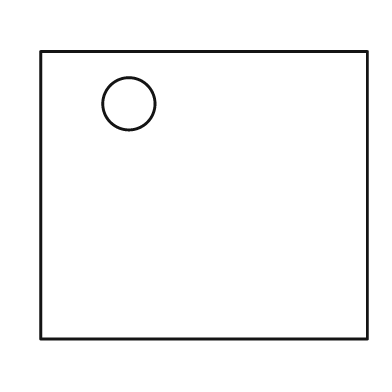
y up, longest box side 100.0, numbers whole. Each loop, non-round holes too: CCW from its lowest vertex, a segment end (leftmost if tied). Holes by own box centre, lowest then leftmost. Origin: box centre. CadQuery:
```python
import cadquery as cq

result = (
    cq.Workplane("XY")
    .moveTo(-50.0, -44.0)
    .lineTo(50.0, -44.0)
    .lineTo(50.0, 44.0)
    .lineTo(-50.0, 44.0)
    .close()
    .moveTo(-23.0, 28.0)
    .circle(8.0)
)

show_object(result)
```